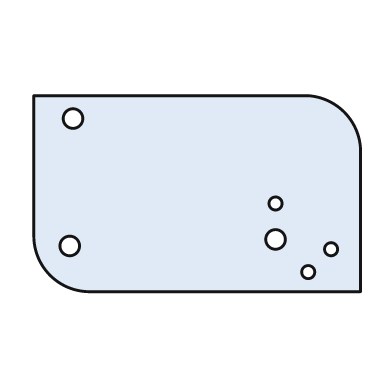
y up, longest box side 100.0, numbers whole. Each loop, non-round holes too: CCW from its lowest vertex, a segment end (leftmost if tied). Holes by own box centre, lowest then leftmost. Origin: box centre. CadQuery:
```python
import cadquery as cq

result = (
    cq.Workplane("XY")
    .moveTo(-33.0, -30.0)
    .lineTo(50.0, -30.0)
    .lineTo(50.0, 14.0)
    .threePointArc((45.0, 25.0), (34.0, 30.0))
    .lineTo(-50.0, 30.0)
    .lineTo(-50.0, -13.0)
    .threePointArc((-45.0, -25.0), (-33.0, -30.0))
    .close()
    .moveTo(34.0, -24.0)
    .circle(2.0)
    .moveTo(41.0, -17.0)
    .circle(2.0)
    .moveTo(-39.0, -16.0)
    .circle(3.0)
    .moveTo(24.0, -14.0)
    .circle(3.0)
    .moveTo(24.0, -3.0)
    .circle(2.0)
    .moveTo(-38.0, 23.0)
    .circle(3.0)
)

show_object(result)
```